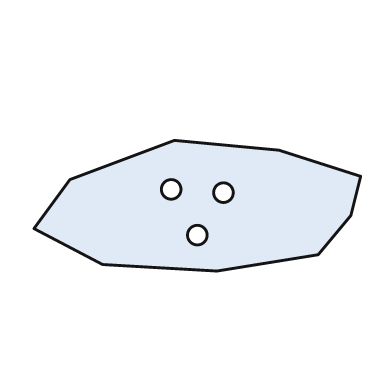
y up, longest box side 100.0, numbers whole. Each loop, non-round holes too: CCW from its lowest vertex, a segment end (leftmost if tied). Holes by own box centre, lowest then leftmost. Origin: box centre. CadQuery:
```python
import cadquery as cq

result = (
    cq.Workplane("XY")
    .moveTo(6.0, -20.0)
    .lineTo(37.0, -15.0)
    .lineTo(47.0, -3.0)
    .lineTo(50.0, 9.0)
    .lineTo(25.0, 17.0)
    .lineTo(-7.0, 20.0)
    .lineTo(-39.0, 8.0)
    .lineTo(-50.0, -7.0)
    .lineTo(-29.0, -18.0)
    .close()
    .moveTo(0.0, -9.0)
    .circle(3.0)
    .moveTo(8.0, 4.0)
    .circle(3.0)
    .moveTo(-8.0, 5.0)
    .circle(3.0)
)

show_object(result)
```